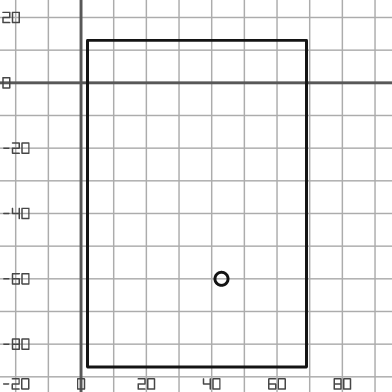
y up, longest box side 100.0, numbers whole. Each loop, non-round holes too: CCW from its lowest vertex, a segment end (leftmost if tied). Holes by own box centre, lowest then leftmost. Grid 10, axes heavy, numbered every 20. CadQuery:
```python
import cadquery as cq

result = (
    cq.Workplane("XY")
    .moveTo(2.0, -87.0)
    .lineTo(69.0, -87.0)
    .lineTo(69.0, 13.0)
    .lineTo(2.0, 13.0)
    .close()
    .moveTo(43.0, -60.0)
    .circle(2.0)
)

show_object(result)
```